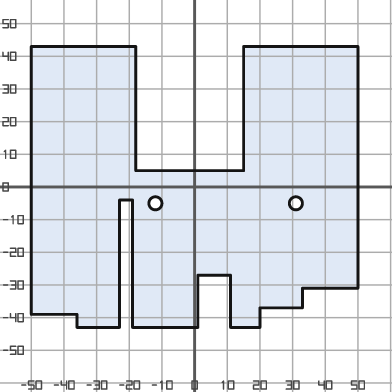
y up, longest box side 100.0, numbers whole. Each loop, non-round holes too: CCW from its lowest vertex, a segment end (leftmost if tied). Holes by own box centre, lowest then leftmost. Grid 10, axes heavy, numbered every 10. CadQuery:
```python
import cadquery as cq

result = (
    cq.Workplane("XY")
    .moveTo(-36.0, -43.0)
    .lineTo(-23.0, -43.0)
    .lineTo(-23.0, -4.0)
    .lineTo(-19.0, -4.0)
    .lineTo(-19.0, -43.0)
    .lineTo(1.0, -43.0)
    .lineTo(1.0, -27.0)
    .lineTo(11.0, -27.0)
    .lineTo(11.0, -43.0)
    .lineTo(20.0, -43.0)
    .lineTo(20.0, -37.0)
    .lineTo(33.0, -37.0)
    .lineTo(33.0, -31.0)
    .lineTo(50.0, -31.0)
    .lineTo(50.0, 43.0)
    .lineTo(15.0, 43.0)
    .lineTo(15.0, 5.0)
    .lineTo(-18.0, 5.0)
    .lineTo(-18.0, 43.0)
    .lineTo(-50.0, 43.0)
    .lineTo(-50.0, -39.0)
    .lineTo(-36.0, -39.0)
    .close()
    .moveTo(-12.0, -5.0)
    .circle(2.0)
    .moveTo(31.0, -5.0)
    .circle(2.0)
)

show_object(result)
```